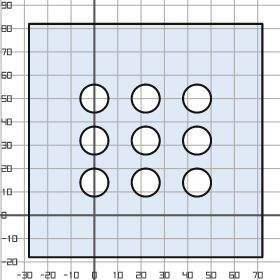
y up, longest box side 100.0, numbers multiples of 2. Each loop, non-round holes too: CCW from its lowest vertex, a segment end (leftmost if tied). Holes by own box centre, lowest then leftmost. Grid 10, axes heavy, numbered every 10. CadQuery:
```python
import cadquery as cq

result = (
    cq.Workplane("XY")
    .moveTo(-28.0, -18.0)
    .lineTo(72.0, -18.0)
    .lineTo(72.0, 82.0)
    .lineTo(-28.0, 82.0)
    .close()
    .moveTo(0.0, 14.0)
    .circle(6.0)
    .moveTo(22.0, 14.0)
    .circle(6.0)
    .moveTo(44.0, 14.0)
    .circle(6.0)
    .moveTo(0.0, 32.0)
    .circle(6.0)
    .moveTo(22.0, 32.0)
    .circle(6.0)
    .moveTo(44.0, 32.0)
    .circle(6.0)
    .moveTo(0.0, 50.0)
    .circle(6.0)
    .moveTo(22.0, 50.0)
    .circle(6.0)
    .moveTo(44.0, 50.0)
    .circle(6.0)
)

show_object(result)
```